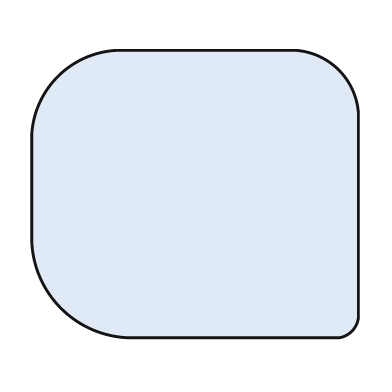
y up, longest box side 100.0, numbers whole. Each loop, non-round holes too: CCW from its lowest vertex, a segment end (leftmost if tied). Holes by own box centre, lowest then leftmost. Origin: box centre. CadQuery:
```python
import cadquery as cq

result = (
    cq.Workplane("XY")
    .moveTo(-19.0, -44.0)
    .lineTo(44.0, -44.0)
    .threePointArc((48.0, -42.0), (50.0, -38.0))
    .lineTo(50.0, 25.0)
    .threePointArc((44.0, 38.0), (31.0, 44.0))
    .lineTo(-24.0, 44.0)
    .threePointArc((-42.0, 36.0), (-50.0, 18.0))
    .lineTo(-50.0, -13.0)
    .threePointArc((-41.0, -35.0), (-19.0, -44.0))
    .close()
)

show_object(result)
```